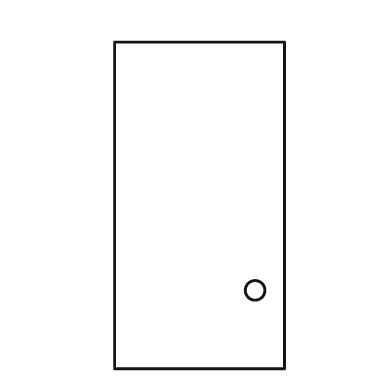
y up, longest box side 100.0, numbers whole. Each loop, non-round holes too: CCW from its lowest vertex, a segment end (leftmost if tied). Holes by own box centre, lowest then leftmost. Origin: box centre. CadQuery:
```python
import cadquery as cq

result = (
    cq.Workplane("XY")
    .moveTo(-26.0, -50.0)
    .lineTo(26.0, -50.0)
    .lineTo(26.0, 50.0)
    .lineTo(-26.0, 50.0)
    .close()
    .moveTo(17.0, -26.0)
    .circle(3.0)
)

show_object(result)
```